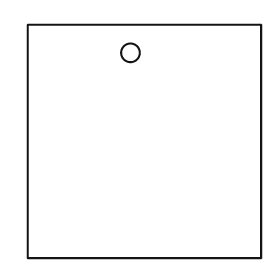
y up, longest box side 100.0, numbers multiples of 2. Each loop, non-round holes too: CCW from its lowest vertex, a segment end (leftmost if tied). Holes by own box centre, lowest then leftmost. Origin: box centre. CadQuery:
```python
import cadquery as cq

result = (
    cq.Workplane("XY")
    .moveTo(-50.0, -50.0)
    .lineTo(50.0, -50.0)
    .lineTo(50.0, 50.0)
    .lineTo(-50.0, 50.0)
    .close()
    .moveTo(-6.0, 38.0)
    .circle(4.0)
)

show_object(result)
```